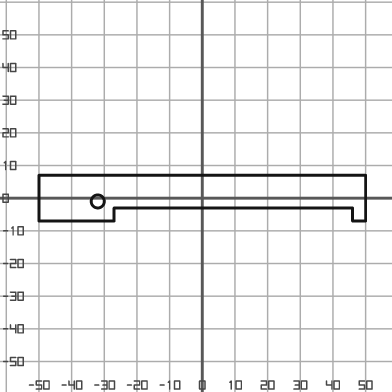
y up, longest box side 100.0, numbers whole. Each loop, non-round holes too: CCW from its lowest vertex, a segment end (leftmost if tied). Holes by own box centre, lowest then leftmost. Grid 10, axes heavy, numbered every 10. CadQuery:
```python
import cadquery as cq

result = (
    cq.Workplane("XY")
    .moveTo(-50.0, -7.0)
    .lineTo(-27.0, -7.0)
    .lineTo(-27.0, -3.0)
    .lineTo(46.0, -3.0)
    .lineTo(46.0, -7.0)
    .lineTo(50.0, -7.0)
    .lineTo(50.0, 7.0)
    .lineTo(-50.0, 7.0)
    .close()
    .moveTo(-32.0, -1.0)
    .circle(2.0)
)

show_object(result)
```